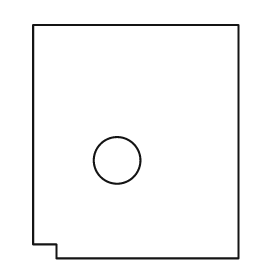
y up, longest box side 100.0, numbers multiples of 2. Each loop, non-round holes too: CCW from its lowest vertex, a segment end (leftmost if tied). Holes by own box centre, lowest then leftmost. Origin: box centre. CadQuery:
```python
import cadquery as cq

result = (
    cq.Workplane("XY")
    .moveTo(-34.0, -50.0)
    .lineTo(44.0, -50.0)
    .lineTo(44.0, 50.0)
    .lineTo(-44.0, 50.0)
    .lineTo(-44.0, -44.0)
    .lineTo(-34.0, -44.0)
    .close()
    .moveTo(-8.0, -8.0)
    .circle(10.0)
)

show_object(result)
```